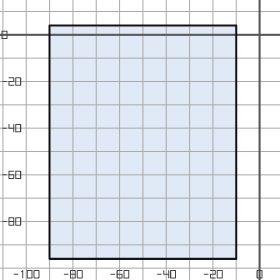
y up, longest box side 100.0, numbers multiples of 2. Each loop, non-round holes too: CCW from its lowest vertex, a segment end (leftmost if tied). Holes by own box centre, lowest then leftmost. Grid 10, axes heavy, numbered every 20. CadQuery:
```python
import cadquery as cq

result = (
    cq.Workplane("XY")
    .moveTo(-90.0, -96.0)
    .lineTo(-10.0, -96.0)
    .lineTo(-10.0, 4.0)
    .lineTo(-90.0, 4.0)
    .close()
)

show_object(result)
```